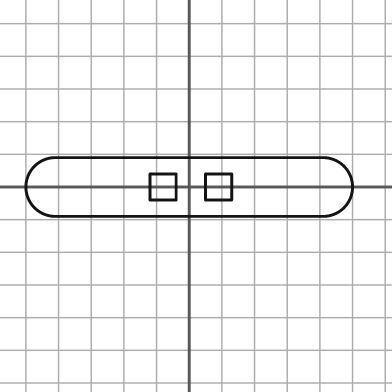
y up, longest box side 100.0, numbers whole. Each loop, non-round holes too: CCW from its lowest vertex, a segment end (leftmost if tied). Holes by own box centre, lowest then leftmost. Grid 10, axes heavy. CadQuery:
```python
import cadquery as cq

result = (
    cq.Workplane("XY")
    .moveTo(-41.0, -9.0)
    .lineTo(41.0, -9.0)
    .threePointArc((50.0, 0.0), (41.0, 9.0))
    .lineTo(-41.0, 9.0)
    .threePointArc((-50.0, 0.0), (-41.0, -9.0))
    .close()
    .moveTo(-12.0, -4.0)
    .lineTo(-4.0, -4.0)
    .lineTo(-4.0, 4.0)
    .lineTo(-12.0, 4.0)
    .close()
    .moveTo(5.0, -4.0)
    .lineTo(13.0, -4.0)
    .lineTo(13.0, 4.0)
    .lineTo(5.0, 4.0)
    .close()
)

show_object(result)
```